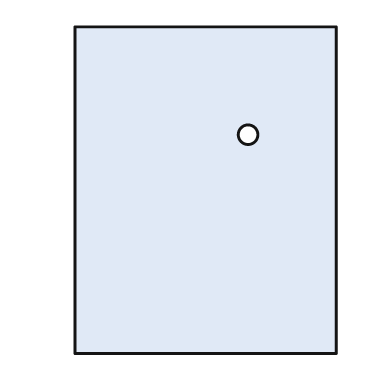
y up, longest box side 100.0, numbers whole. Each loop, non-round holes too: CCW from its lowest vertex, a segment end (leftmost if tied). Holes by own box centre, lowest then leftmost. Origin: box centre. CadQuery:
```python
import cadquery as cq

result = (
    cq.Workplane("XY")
    .moveTo(-40.0, -50.0)
    .lineTo(40.0, -50.0)
    .lineTo(40.0, 50.0)
    .lineTo(-40.0, 50.0)
    .close()
    .moveTo(13.0, 17.0)
    .circle(3.0)
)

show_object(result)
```